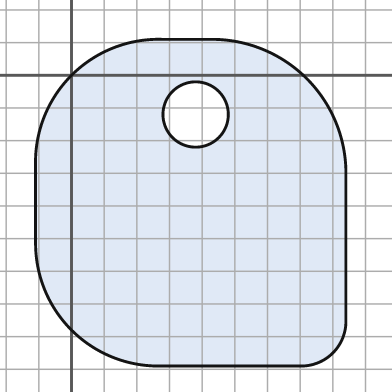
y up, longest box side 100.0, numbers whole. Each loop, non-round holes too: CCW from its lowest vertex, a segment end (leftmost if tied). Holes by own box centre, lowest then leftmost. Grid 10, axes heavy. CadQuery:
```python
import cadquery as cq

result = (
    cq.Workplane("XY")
    .moveTo(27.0, -89.0)
    .lineTo(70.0, -89.0)
    .threePointArc((80.0, -85.0), (84.0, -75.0))
    .lineTo(84.0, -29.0)
    .threePointArc((72.0, -1.0), (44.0, 11.0))
    .lineTo(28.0, 11.0)
    .threePointArc((0.0, 0.0), (-11.0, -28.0))
    .lineTo(-11.0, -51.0)
    .threePointArc((0.0, -78.0), (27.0, -89.0))
    .close()
    .moveTo(38.0, -12.0)
    .circle(10.0)
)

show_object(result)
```